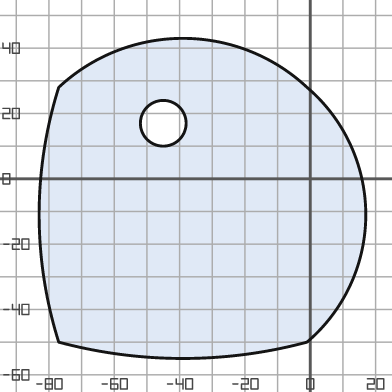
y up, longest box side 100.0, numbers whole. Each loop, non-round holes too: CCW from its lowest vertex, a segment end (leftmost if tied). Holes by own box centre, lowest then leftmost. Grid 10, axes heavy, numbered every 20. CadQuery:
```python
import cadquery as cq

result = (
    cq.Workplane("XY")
    .moveTo(-77.0, -50.0)
    .threePointArc((-39.0, -55.0), (-1.0, -50.0))
    .threePointArc((17.0, -11.0), (-1.0, 28.0))
    .threePointArc((-39.0, 43.0), (-77.0, 28.0))
    .threePointArc((-83.0, -11.0), (-77.0, -50.0))
    .close()
    .moveTo(-45.0, 17.0)
    .circle(7.0)
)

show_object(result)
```